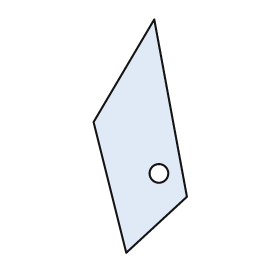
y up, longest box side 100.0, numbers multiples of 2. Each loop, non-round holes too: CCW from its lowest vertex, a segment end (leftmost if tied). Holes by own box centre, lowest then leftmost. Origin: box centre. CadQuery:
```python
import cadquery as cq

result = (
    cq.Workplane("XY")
    .moveTo(-6.0, -50.0)
    .lineTo(20.0, -26.0)
    .lineTo(6.0, 50.0)
    .lineTo(-20.0, 6.0)
    .close()
    .moveTo(8.0, -16.0)
    .circle(4.0)
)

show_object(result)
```